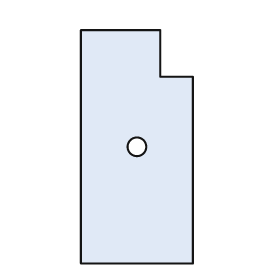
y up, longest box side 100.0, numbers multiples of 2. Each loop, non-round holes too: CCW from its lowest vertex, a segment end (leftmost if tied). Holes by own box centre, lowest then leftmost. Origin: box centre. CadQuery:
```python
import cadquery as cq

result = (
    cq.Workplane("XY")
    .moveTo(-24.0, -50.0)
    .lineTo(24.0, -50.0)
    .lineTo(24.0, 30.0)
    .lineTo(10.0, 30.0)
    .lineTo(10.0, 50.0)
    .lineTo(-24.0, 50.0)
    .close()
    .moveTo(0.0, 0.0)
    .circle(4.0)
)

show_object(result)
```